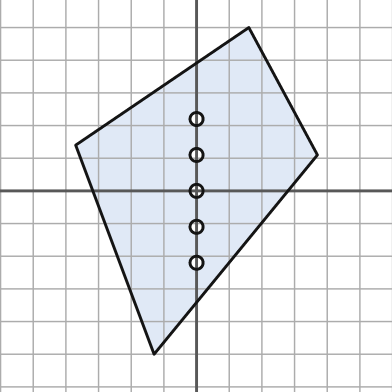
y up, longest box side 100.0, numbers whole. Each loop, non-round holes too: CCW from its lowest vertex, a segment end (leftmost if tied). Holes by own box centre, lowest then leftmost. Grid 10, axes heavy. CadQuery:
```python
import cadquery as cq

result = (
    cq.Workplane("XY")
    .moveTo(-13.0, -50.0)
    .lineTo(37.0, 11.0)
    .lineTo(16.0, 50.0)
    .lineTo(-37.0, 14.0)
    .close()
    .moveTo(0.0, -22.0)
    .circle(2.0)
    .moveTo(0.0, -11.0)
    .circle(2.0)
    .moveTo(0.0, 0.0)
    .circle(2.0)
    .moveTo(0.0, 11.0)
    .circle(2.0)
    .moveTo(0.0, 22.0)
    .circle(2.0)
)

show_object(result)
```